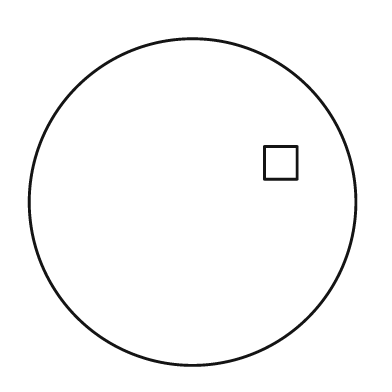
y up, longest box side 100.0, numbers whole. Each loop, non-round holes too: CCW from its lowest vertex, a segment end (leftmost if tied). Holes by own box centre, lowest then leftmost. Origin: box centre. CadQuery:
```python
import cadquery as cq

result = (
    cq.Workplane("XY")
    .moveTo(0.0, 0.0)
    .circle(50.0)
    .moveTo(22.0, 7.0)
    .lineTo(32.0, 7.0)
    .lineTo(32.0, 17.0)
    .lineTo(22.0, 17.0)
    .close()
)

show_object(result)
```